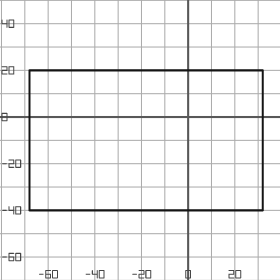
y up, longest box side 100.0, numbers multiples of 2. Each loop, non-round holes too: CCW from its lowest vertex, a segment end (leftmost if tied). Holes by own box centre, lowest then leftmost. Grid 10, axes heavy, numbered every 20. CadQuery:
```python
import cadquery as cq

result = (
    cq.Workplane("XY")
    .moveTo(-68.0, -40.0)
    .lineTo(32.0, -40.0)
    .lineTo(32.0, 20.0)
    .lineTo(-68.0, 20.0)
    .close()
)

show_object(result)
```